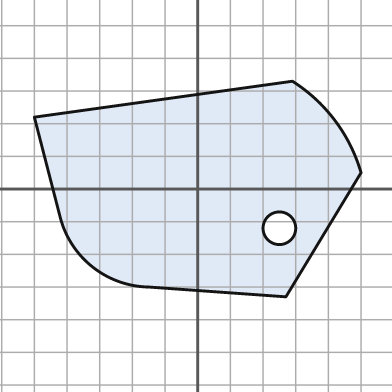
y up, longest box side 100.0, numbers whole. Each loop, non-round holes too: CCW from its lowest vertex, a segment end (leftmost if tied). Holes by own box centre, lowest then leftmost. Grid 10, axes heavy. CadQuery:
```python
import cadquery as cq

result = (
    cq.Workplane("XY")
    .moveTo(27.0, -33.0)
    .lineTo(50.0, 5.0)
    .threePointArc((42.0, 21.0), (29.0, 33.0))
    .lineTo(-50.0, 22.0)
    .lineTo(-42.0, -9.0)
    .threePointArc((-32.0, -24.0), (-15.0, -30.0))
    .close()
    .moveTo(25.0, -12.0)
    .circle(5.0)
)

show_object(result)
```